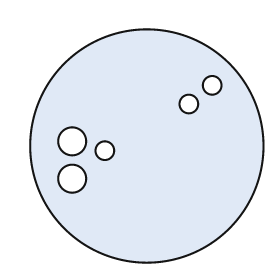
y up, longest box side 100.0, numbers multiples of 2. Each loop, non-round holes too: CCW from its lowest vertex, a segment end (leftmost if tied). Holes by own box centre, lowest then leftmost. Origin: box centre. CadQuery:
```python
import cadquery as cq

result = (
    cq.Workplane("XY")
    .moveTo(0.0, 0.0)
    .circle(50.0)
    .moveTo(-32.0, -14.0)
    .circle(6.0)
    .moveTo(-18.0, -2.0)
    .circle(4.0)
    .moveTo(-32.0, 2.0)
    .circle(6.0)
    .moveTo(18.0, 18.0)
    .circle(4.0)
    .moveTo(28.0, 26.0)
    .circle(4.0)
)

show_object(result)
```